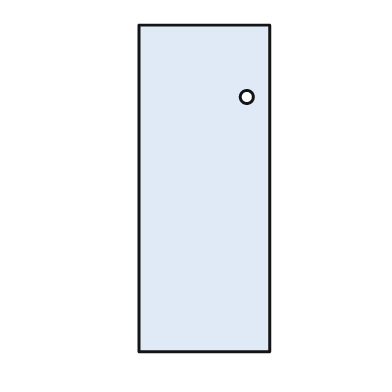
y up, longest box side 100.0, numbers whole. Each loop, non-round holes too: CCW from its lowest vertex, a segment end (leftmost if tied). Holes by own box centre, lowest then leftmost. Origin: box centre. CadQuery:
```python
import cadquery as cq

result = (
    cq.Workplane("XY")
    .moveTo(-20.0, -50.0)
    .lineTo(20.0, -50.0)
    .lineTo(20.0, 50.0)
    .lineTo(-20.0, 50.0)
    .close()
    .moveTo(13.0, 28.0)
    .circle(2.0)
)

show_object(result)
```